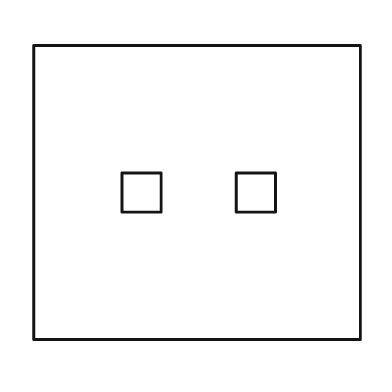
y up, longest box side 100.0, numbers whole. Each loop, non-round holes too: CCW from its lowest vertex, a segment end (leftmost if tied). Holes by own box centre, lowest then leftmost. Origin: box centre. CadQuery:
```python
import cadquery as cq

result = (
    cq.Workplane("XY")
    .moveTo(-50.0, -45.0)
    .lineTo(50.0, -45.0)
    .lineTo(50.0, 45.0)
    .lineTo(-50.0, 45.0)
    .close()
    .moveTo(-23.0, -6.0)
    .lineTo(-11.0, -6.0)
    .lineTo(-11.0, 6.0)
    .lineTo(-23.0, 6.0)
    .close()
    .moveTo(12.0, -6.0)
    .lineTo(24.0, -6.0)
    .lineTo(24.0, 6.0)
    .lineTo(12.0, 6.0)
    .close()
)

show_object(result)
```